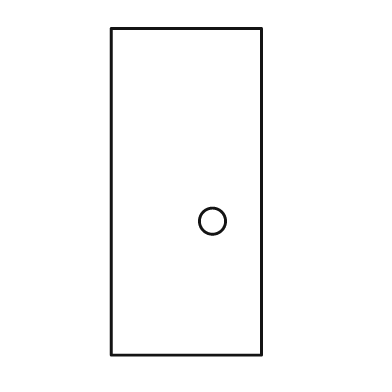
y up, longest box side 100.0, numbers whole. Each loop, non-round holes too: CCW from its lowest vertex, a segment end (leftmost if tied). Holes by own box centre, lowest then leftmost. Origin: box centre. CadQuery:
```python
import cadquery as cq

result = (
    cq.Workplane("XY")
    .moveTo(-23.0, -50.0)
    .lineTo(23.0, -50.0)
    .lineTo(23.0, 50.0)
    .lineTo(-23.0, 50.0)
    .close()
    .moveTo(8.0, -9.0)
    .circle(4.0)
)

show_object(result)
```